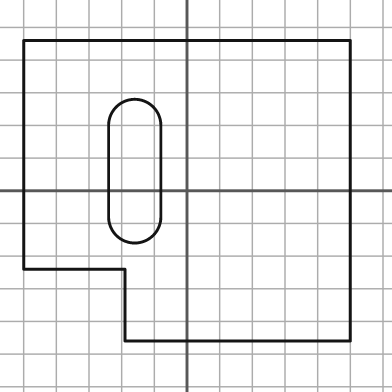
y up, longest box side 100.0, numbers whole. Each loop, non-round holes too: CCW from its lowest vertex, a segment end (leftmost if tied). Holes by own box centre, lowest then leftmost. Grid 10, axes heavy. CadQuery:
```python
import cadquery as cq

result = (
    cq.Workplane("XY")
    .moveTo(-19.0, -46.0)
    .lineTo(50.0, -46.0)
    .lineTo(50.0, 46.0)
    .lineTo(-50.0, 46.0)
    .lineTo(-50.0, -24.0)
    .lineTo(-19.0, -24.0)
    .close()
    .moveTo(-24.0, -8.0)
    .threePointArc((-16.0, -16.0), (-8.0, -8.0))
    .lineTo(-8.0, 20.0)
    .threePointArc((-16.0, 28.0), (-24.0, 20.0))
    .close()
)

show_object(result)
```